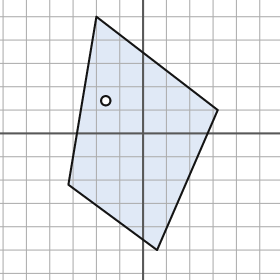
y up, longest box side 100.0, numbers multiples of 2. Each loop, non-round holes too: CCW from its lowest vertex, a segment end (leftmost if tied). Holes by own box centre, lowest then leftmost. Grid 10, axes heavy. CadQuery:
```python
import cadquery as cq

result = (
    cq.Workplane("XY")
    .moveTo(6.0, -50.0)
    .lineTo(32.0, 10.0)
    .lineTo(-20.0, 50.0)
    .lineTo(-32.0, -22.0)
    .close()
    .moveTo(-16.0, 14.0)
    .circle(2.0)
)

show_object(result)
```